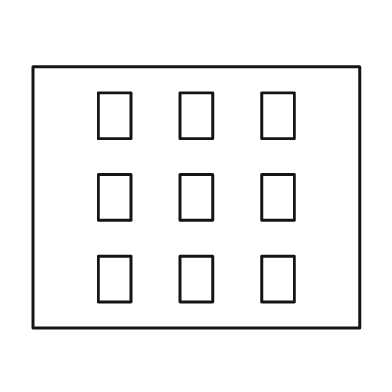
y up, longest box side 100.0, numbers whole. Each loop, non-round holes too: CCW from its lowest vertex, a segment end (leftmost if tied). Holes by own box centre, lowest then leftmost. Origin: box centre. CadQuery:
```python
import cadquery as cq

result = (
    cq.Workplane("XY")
    .moveTo(-50.0, -40.0)
    .lineTo(50.0, -40.0)
    .lineTo(50.0, 40.0)
    .lineTo(-50.0, 40.0)
    .close()
    .moveTo(-30.0, -32.0)
    .lineTo(-20.0, -32.0)
    .lineTo(-20.0, -18.0)
    .lineTo(-30.0, -18.0)
    .close()
    .moveTo(-5.0, -32.0)
    .lineTo(5.0, -32.0)
    .lineTo(5.0, -18.0)
    .lineTo(-5.0, -18.0)
    .close()
    .moveTo(20.0, -32.0)
    .lineTo(30.0, -32.0)
    .lineTo(30.0, -18.0)
    .lineTo(20.0, -18.0)
    .close()
    .moveTo(-30.0, -7.0)
    .lineTo(-20.0, -7.0)
    .lineTo(-20.0, 7.0)
    .lineTo(-30.0, 7.0)
    .close()
    .moveTo(-5.0, -7.0)
    .lineTo(5.0, -7.0)
    .lineTo(5.0, 7.0)
    .lineTo(-5.0, 7.0)
    .close()
    .moveTo(20.0, -7.0)
    .lineTo(30.0, -7.0)
    .lineTo(30.0, 7.0)
    .lineTo(20.0, 7.0)
    .close()
    .moveTo(-30.0, 18.0)
    .lineTo(-20.0, 18.0)
    .lineTo(-20.0, 32.0)
    .lineTo(-30.0, 32.0)
    .close()
    .moveTo(-5.0, 18.0)
    .lineTo(5.0, 18.0)
    .lineTo(5.0, 32.0)
    .lineTo(-5.0, 32.0)
    .close()
    .moveTo(20.0, 18.0)
    .lineTo(30.0, 18.0)
    .lineTo(30.0, 32.0)
    .lineTo(20.0, 32.0)
    .close()
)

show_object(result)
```